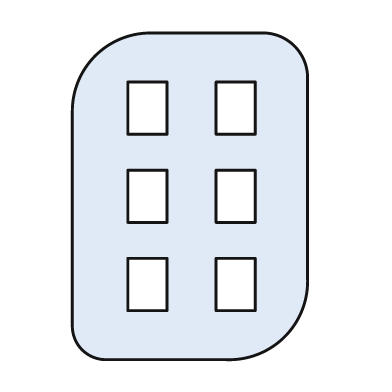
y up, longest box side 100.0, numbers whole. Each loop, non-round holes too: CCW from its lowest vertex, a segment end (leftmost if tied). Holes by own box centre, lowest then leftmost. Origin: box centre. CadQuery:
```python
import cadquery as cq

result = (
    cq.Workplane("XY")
    .moveTo(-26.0, -50.0)
    .lineTo(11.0, -50.0)
    .threePointArc((29.0, -43.0), (36.0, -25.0))
    .lineTo(36.0, 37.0)
    .threePointArc((32.0, 46.0), (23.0, 50.0))
    .lineTo(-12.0, 50.0)
    .threePointArc((-29.0, 43.0), (-36.0, 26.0))
    .lineTo(-36.0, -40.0)
    .threePointArc((-33.0, -47.0), (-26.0, -50.0))
    .close()
    .moveTo(-19.0, -35.0)
    .lineTo(-7.0, -35.0)
    .lineTo(-7.0, -19.0)
    .lineTo(-19.0, -19.0)
    .close()
    .moveTo(8.0, -35.0)
    .lineTo(20.0, -35.0)
    .lineTo(20.0, -19.0)
    .lineTo(8.0, -19.0)
    .close()
    .moveTo(-19.0, -8.0)
    .lineTo(-7.0, -8.0)
    .lineTo(-7.0, 8.0)
    .lineTo(-19.0, 8.0)
    .close()
    .moveTo(8.0, -8.0)
    .lineTo(20.0, -8.0)
    .lineTo(20.0, 8.0)
    .lineTo(8.0, 8.0)
    .close()
    .moveTo(-19.0, 19.0)
    .lineTo(-7.0, 19.0)
    .lineTo(-7.0, 35.0)
    .lineTo(-19.0, 35.0)
    .close()
    .moveTo(8.0, 19.0)
    .lineTo(20.0, 19.0)
    .lineTo(20.0, 35.0)
    .lineTo(8.0, 35.0)
    .close()
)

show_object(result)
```